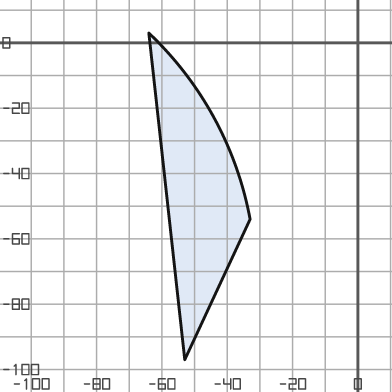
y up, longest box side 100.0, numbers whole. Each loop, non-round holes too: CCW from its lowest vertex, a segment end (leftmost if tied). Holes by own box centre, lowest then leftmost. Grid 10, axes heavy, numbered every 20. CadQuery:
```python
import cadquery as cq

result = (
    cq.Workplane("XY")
    .moveTo(-53.0, -97.0)
    .lineTo(-33.0, -54.0)
    .threePointArc((-44.0, -23.0), (-64.0, 3.0))
    .close()
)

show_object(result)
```